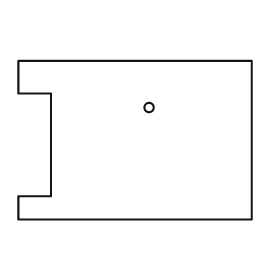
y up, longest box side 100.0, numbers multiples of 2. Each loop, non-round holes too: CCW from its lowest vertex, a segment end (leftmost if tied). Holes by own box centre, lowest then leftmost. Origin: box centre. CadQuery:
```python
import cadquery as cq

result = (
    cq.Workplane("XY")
    .moveTo(-50.0, -34.0)
    .lineTo(50.0, -34.0)
    .lineTo(50.0, 34.0)
    .lineTo(-50.0, 34.0)
    .lineTo(-50.0, 20.0)
    .lineTo(-36.0, 20.0)
    .lineTo(-36.0, -24.0)
    .lineTo(-50.0, -24.0)
    .close()
    .moveTo(6.0, 14.0)
    .circle(2.0)
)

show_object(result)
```